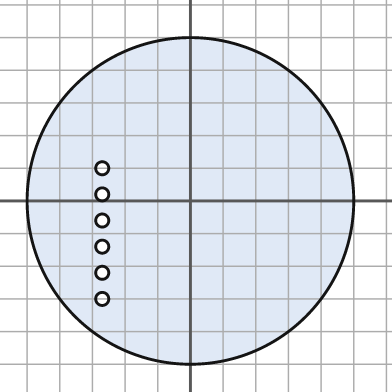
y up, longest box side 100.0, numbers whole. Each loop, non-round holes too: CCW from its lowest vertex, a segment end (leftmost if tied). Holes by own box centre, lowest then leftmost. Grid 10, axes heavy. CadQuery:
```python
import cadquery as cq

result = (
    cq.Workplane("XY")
    .moveTo(0.0, 0.0)
    .circle(50.0)
    .moveTo(-27.0, -30.0)
    .circle(2.0)
    .moveTo(-27.0, -22.0)
    .circle(2.0)
    .moveTo(-27.0, -14.0)
    .circle(2.0)
    .moveTo(-27.0, -6.0)
    .circle(2.0)
    .moveTo(-27.0, 2.0)
    .circle(2.0)
    .moveTo(-27.0, 10.0)
    .circle(2.0)
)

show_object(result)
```